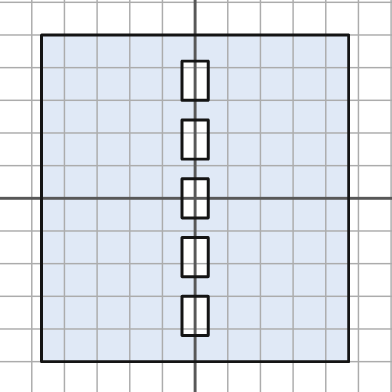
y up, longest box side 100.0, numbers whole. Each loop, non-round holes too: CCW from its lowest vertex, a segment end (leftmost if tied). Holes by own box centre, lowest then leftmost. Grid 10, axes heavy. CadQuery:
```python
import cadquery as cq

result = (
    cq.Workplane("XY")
    .moveTo(-47.0, -50.0)
    .lineTo(47.0, -50.0)
    .lineTo(47.0, 50.0)
    .lineTo(-47.0, 50.0)
    .close()
    .moveTo(-4.0, -42.0)
    .lineTo(4.0, -42.0)
    .lineTo(4.0, -30.0)
    .lineTo(-4.0, -30.0)
    .close()
    .moveTo(-4.0, -24.0)
    .lineTo(4.0, -24.0)
    .lineTo(4.0, -12.0)
    .lineTo(-4.0, -12.0)
    .close()
    .moveTo(-4.0, -6.0)
    .lineTo(4.0, -6.0)
    .lineTo(4.0, 6.0)
    .lineTo(-4.0, 6.0)
    .close()
    .moveTo(-4.0, 12.0)
    .lineTo(4.0, 12.0)
    .lineTo(4.0, 24.0)
    .lineTo(-4.0, 24.0)
    .close()
    .moveTo(-4.0, 30.0)
    .lineTo(4.0, 30.0)
    .lineTo(4.0, 42.0)
    .lineTo(-4.0, 42.0)
    .close()
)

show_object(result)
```